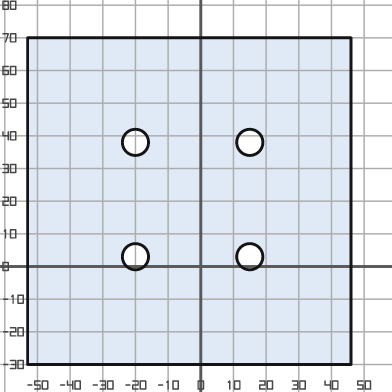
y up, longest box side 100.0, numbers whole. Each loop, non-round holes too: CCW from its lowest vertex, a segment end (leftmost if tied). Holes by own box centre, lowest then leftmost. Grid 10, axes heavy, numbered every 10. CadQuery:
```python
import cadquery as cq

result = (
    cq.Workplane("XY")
    .moveTo(-53.0, -30.0)
    .lineTo(46.0, -30.0)
    .lineTo(46.0, 70.0)
    .lineTo(-53.0, 70.0)
    .close()
    .moveTo(-20.0, 3.0)
    .circle(4.0)
    .moveTo(15.0, 3.0)
    .circle(4.0)
    .moveTo(-20.0, 38.0)
    .circle(4.0)
    .moveTo(15.0, 38.0)
    .circle(4.0)
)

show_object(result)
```